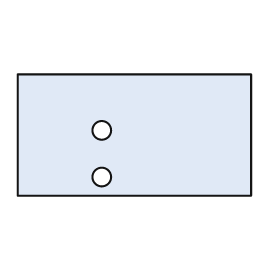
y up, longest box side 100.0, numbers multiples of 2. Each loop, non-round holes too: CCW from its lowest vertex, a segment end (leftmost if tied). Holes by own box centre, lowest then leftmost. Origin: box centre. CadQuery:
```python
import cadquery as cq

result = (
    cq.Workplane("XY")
    .moveTo(-50.0, -26.0)
    .lineTo(50.0, -26.0)
    .lineTo(50.0, 26.0)
    .lineTo(-50.0, 26.0)
    .close()
    .moveTo(-14.0, -18.0)
    .circle(4.0)
    .moveTo(-14.0, 2.0)
    .circle(4.0)
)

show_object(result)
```